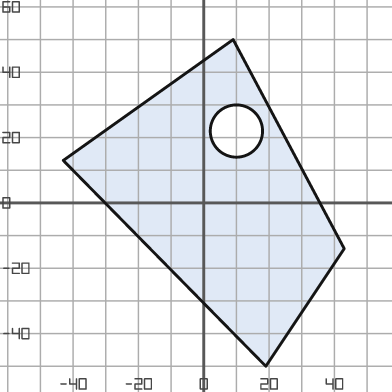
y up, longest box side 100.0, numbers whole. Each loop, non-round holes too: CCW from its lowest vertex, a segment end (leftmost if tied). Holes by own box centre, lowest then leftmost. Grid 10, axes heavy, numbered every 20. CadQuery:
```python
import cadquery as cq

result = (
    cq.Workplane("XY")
    .moveTo(19.0, -50.0)
    .lineTo(43.0, -14.0)
    .lineTo(9.0, 50.0)
    .lineTo(-43.0, 13.0)
    .close()
    .moveTo(10.0, 22.0)
    .circle(8.0)
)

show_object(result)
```